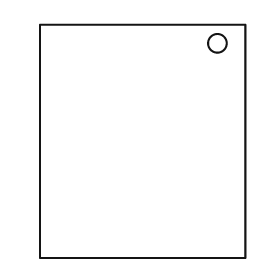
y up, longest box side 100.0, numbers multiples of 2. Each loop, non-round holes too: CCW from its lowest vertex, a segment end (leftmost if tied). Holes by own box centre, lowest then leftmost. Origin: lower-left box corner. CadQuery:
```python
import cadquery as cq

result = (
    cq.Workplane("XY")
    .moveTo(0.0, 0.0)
    .lineTo(88.0, 0.0)
    .lineTo(88.0, 100.0)
    .lineTo(0.0, 100.0)
    .close()
    .moveTo(76.0, 92.0)
    .circle(4.0)
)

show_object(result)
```